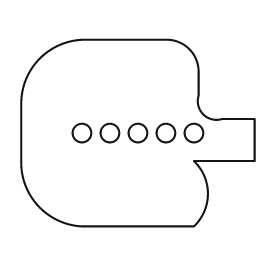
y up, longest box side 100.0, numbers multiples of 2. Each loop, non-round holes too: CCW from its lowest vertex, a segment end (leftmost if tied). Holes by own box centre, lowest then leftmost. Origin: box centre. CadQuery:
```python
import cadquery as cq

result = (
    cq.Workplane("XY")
    .moveTo(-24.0, -40.0)
    .lineTo(24.0, -40.0)
    .threePointArc((30.0, -26.0), (24.0, -12.0))
    .lineTo(50.0, -12.0)
    .lineTo(50.0, 6.0)
    .lineTo(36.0, 6.0)
    .threePointArc((28.0, 8.0), (26.0, 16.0))
    .lineTo(26.0, 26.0)
    .threePointArc((22.0, 36.0), (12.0, 40.0))
    .lineTo(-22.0, 40.0)
    .threePointArc((-42.0, 32.0), (-50.0, 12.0))
    .lineTo(-50.0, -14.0)
    .threePointArc((-42.0, -32.0), (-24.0, -40.0))
    .close()
    .moveTo(-24.0, 0.0)
    .circle(4.0)
    .moveTo(-12.0, 0.0)
    .circle(4.0)
    .moveTo(0.0, 0.0)
    .circle(4.0)
    .moveTo(12.0, 0.0)
    .circle(4.0)
    .moveTo(24.0, 0.0)
    .circle(4.0)
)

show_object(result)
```